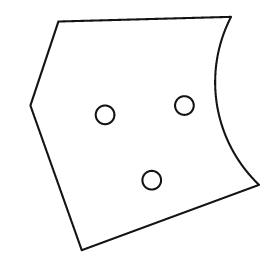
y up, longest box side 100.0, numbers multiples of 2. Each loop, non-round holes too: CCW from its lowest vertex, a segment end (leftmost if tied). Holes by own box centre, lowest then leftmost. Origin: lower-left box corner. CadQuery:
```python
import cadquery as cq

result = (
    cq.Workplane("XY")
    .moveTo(22.0, 0.0)
    .lineTo(98.0, 28.0)
    .threePointArc((80.0, 62.0), (86.0, 100.0))
    .lineTo(12.0, 98.0)
    .lineTo(0.0, 62.0)
    .close()
    .moveTo(52.0, 30.0)
    .circle(4.0)
    .moveTo(32.0, 58.0)
    .circle(4.0)
    .moveTo(66.0, 62.0)
    .circle(4.0)
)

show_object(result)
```